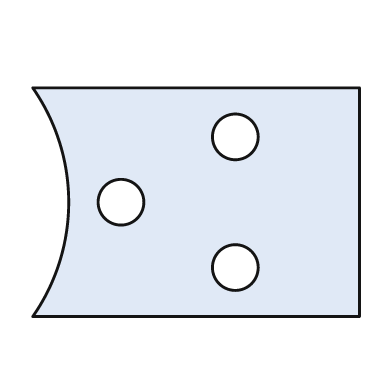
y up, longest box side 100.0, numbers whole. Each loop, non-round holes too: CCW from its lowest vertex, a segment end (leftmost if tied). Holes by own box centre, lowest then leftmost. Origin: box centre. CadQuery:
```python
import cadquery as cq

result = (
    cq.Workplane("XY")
    .moveTo(-50.0, -35.0)
    .lineTo(50.0, -35.0)
    .lineTo(50.0, 35.0)
    .lineTo(-50.0, 35.0)
    .threePointArc((-39.0, 0.0), (-50.0, -35.0))
    .close()
    .moveTo(12.0, -20.0)
    .circle(7.0)
    .moveTo(-23.0, 0.0)
    .circle(7.0)
    .moveTo(12.0, 20.0)
    .circle(7.0)
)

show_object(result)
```